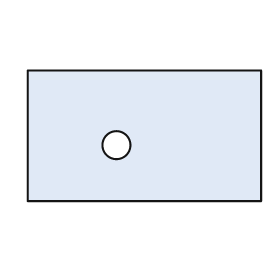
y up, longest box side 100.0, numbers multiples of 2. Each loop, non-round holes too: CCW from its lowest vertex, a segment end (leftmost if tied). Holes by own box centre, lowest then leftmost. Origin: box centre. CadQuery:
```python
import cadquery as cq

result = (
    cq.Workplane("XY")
    .moveTo(-50.0, -28.0)
    .lineTo(50.0, -28.0)
    .lineTo(50.0, 28.0)
    .lineTo(-50.0, 28.0)
    .close()
    .moveTo(-12.0, -4.0)
    .circle(6.0)
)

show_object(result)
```